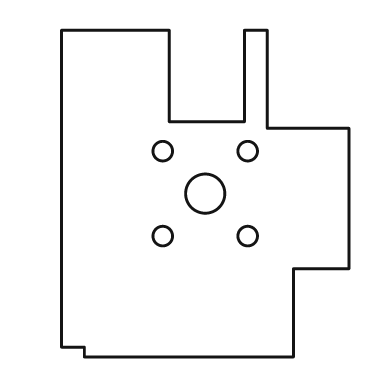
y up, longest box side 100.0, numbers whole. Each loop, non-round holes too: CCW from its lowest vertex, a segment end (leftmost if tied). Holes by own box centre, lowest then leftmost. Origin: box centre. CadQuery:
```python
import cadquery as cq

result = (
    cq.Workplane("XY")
    .moveTo(-37.0, -50.0)
    .lineTo(27.0, -50.0)
    .lineTo(27.0, -23.0)
    .lineTo(44.0, -23.0)
    .lineTo(44.0, 20.0)
    .lineTo(19.0, 20.0)
    .lineTo(19.0, 50.0)
    .lineTo(12.0, 50.0)
    .lineTo(12.0, 22.0)
    .lineTo(-11.0, 22.0)
    .lineTo(-11.0, 50.0)
    .lineTo(-44.0, 50.0)
    .lineTo(-44.0, -47.0)
    .lineTo(-37.0, -47.0)
    .close()
    .moveTo(-13.0, -13.0)
    .circle(3.0)
    .moveTo(13.0, -13.0)
    .circle(3.0)
    .moveTo(0.0, 0.0)
    .circle(6.0)
    .moveTo(-13.0, 13.0)
    .circle(3.0)
    .moveTo(13.0, 13.0)
    .circle(3.0)
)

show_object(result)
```